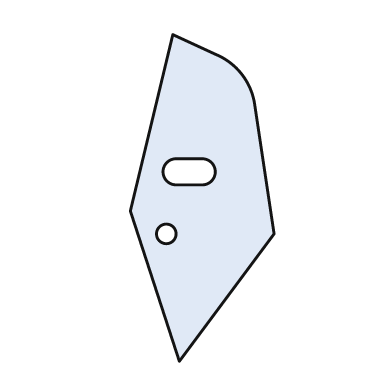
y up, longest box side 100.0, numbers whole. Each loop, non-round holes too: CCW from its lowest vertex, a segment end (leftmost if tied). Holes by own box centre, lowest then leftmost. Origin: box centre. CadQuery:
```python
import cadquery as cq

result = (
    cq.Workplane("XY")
    .moveTo(-7.0, -50.0)
    .lineTo(22.0, -11.0)
    .lineTo(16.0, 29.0)
    .threePointArc((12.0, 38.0), (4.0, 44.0))
    .lineTo(-9.0, 50.0)
    .lineTo(-22.0, -4.0)
    .close()
    .moveTo(-11.0, -11.0)
    .circle(3.0)
    .moveTo(-8.0, 4.0)
    .lineTo(0.0, 4.0)
    .threePointArc((4.0, 8.0), (0.0, 12.0))
    .lineTo(-8.0, 12.0)
    .threePointArc((-12.0, 8.0), (-8.0, 4.0))
    .close()
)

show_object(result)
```